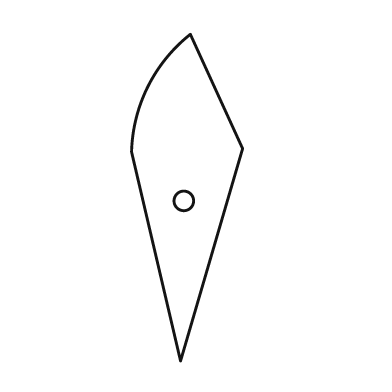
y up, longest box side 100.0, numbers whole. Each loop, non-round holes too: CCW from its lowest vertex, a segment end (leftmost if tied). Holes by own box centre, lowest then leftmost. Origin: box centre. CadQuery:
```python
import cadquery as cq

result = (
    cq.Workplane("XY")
    .moveTo(-2.0, -50.0)
    .lineTo(17.0, 15.0)
    .lineTo(1.0, 50.0)
    .threePointArc((-12.0, 34.0), (-17.0, 14.0))
    .close()
    .moveTo(-1.0, -1.0)
    .circle(3.0)
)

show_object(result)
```